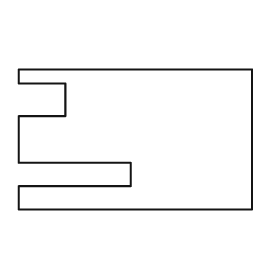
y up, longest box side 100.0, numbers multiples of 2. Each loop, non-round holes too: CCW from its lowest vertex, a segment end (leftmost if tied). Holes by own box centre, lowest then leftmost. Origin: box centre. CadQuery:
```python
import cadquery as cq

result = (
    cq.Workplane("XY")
    .moveTo(-50.0, -30.0)
    .lineTo(50.0, -30.0)
    .lineTo(50.0, 30.0)
    .lineTo(-50.0, 30.0)
    .lineTo(-50.0, 24.0)
    .lineTo(-30.0, 24.0)
    .lineTo(-30.0, 10.0)
    .lineTo(-50.0, 10.0)
    .lineTo(-50.0, -10.0)
    .lineTo(-2.0, -10.0)
    .lineTo(-2.0, -20.0)
    .lineTo(-50.0, -20.0)
    .close()
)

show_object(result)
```